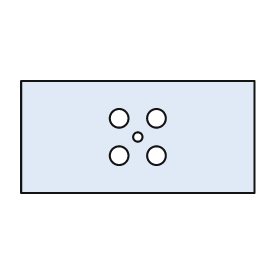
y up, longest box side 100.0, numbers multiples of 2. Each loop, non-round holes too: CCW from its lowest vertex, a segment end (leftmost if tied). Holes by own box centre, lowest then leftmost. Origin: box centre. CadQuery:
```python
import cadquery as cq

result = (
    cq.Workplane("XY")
    .moveTo(-50.0, -24.0)
    .lineTo(50.0, -24.0)
    .lineTo(50.0, 24.0)
    .lineTo(-50.0, 24.0)
    .close()
    .moveTo(-8.0, -8.0)
    .circle(4.0)
    .moveTo(8.0, -8.0)
    .circle(4.0)
    .moveTo(0.0, 0.0)
    .circle(2.0)
    .moveTo(-8.0, 8.0)
    .circle(4.0)
    .moveTo(8.0, 8.0)
    .circle(4.0)
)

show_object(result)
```